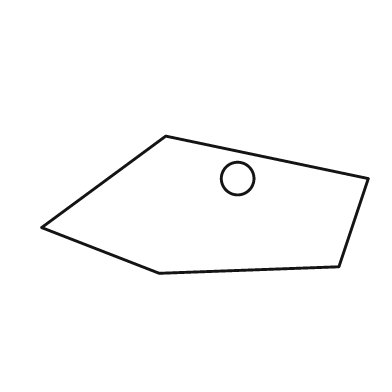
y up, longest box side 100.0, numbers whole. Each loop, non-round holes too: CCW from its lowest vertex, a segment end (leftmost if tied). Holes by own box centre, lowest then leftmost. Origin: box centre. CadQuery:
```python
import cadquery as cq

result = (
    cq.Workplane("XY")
    .moveTo(-14.0, -21.0)
    .lineTo(41.0, -19.0)
    .lineTo(50.0, 8.0)
    .lineTo(-12.0, 21.0)
    .lineTo(-50.0, -7.0)
    .close()
    .moveTo(10.0, 8.0)
    .circle(5.0)
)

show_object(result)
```